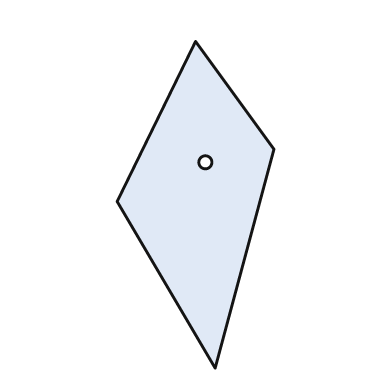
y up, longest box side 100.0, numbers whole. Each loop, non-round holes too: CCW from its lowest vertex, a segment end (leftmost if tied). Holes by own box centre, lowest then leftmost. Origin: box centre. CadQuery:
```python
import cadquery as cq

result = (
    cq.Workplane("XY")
    .moveTo(6.0, -50.0)
    .lineTo(24.0, 17.0)
    .lineTo(0.0, 50.0)
    .lineTo(-24.0, 1.0)
    .close()
    .moveTo(3.0, 13.0)
    .circle(2.0)
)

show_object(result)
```